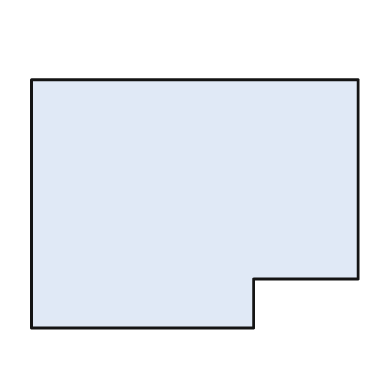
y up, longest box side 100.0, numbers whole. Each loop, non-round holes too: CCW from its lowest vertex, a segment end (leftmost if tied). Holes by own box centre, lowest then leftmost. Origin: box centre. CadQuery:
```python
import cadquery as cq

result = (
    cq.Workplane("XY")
    .moveTo(-50.0, -38.0)
    .lineTo(18.0, -38.0)
    .lineTo(18.0, -23.0)
    .lineTo(50.0, -23.0)
    .lineTo(50.0, 38.0)
    .lineTo(-50.0, 38.0)
    .close()
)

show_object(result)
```